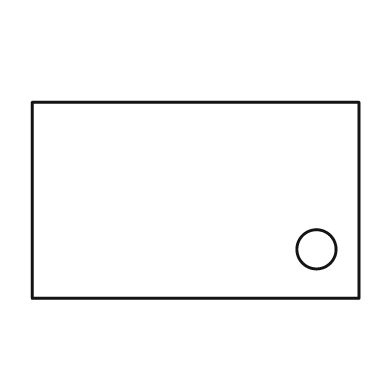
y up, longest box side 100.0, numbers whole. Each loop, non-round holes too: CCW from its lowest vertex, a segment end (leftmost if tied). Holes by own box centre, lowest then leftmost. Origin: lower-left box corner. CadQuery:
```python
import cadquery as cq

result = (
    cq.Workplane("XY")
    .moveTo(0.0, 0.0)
    .lineTo(100.0, 0.0)
    .lineTo(100.0, 60.0)
    .lineTo(0.0, 60.0)
    .close()
    .moveTo(87.0, 15.0)
    .circle(6.0)
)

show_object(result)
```